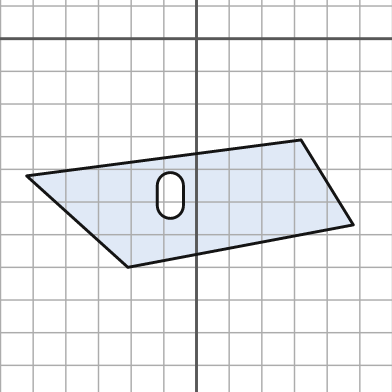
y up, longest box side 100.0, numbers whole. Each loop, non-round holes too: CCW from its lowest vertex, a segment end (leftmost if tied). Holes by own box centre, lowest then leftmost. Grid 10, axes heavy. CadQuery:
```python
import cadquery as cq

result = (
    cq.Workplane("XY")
    .moveTo(-21.0, -70.0)
    .lineTo(48.0, -57.0)
    .lineTo(32.0, -31.0)
    .lineTo(-52.0, -42.0)
    .close()
    .moveTo(-12.0, -51.0)
    .threePointArc((-8.0, -55.0), (-4.0, -51.0))
    .lineTo(-4.0, -45.0)
    .threePointArc((-8.0, -41.0), (-12.0, -45.0))
    .close()
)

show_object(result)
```